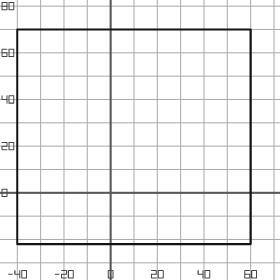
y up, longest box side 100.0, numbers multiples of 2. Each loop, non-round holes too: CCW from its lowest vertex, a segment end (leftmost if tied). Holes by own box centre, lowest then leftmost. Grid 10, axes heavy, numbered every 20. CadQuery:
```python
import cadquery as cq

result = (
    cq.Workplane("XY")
    .moveTo(-40.0, -22.0)
    .lineTo(60.0, -22.0)
    .lineTo(60.0, 70.0)
    .lineTo(-40.0, 70.0)
    .close()
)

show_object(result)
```